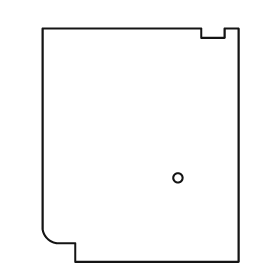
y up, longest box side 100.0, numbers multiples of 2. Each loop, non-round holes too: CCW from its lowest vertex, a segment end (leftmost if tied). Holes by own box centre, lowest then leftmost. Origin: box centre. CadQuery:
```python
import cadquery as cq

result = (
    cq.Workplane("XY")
    .moveTo(-28.0, -50.0)
    .lineTo(42.0, -50.0)
    .lineTo(42.0, 50.0)
    .lineTo(36.0, 50.0)
    .lineTo(36.0, 46.0)
    .lineTo(26.0, 46.0)
    .lineTo(26.0, 50.0)
    .lineTo(-42.0, 50.0)
    .lineTo(-42.0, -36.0)
    .threePointArc((-40.0, -40.0), (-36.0, -42.0))
    .lineTo(-28.0, -42.0)
    .close()
    .moveTo(16.0, -14.0)
    .circle(2.0)
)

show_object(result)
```